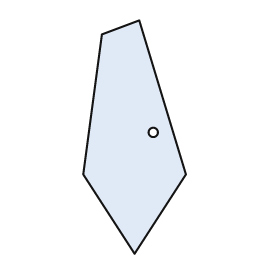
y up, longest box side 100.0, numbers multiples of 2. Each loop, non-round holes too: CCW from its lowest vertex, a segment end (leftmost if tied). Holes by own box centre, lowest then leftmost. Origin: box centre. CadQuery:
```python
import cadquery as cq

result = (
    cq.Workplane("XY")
    .moveTo(0.0, -50.0)
    .lineTo(22.0, -16.0)
    .lineTo(2.0, 50.0)
    .lineTo(-14.0, 44.0)
    .lineTo(-22.0, -16.0)
    .close()
    .moveTo(8.0, 2.0)
    .circle(2.0)
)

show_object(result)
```